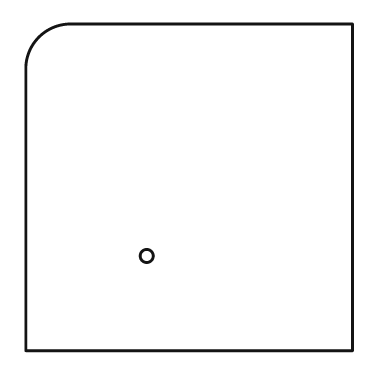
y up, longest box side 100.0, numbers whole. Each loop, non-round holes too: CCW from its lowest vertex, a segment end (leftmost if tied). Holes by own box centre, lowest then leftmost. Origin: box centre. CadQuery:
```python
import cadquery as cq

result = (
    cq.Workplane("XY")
    .moveTo(-50.0, -50.0)
    .lineTo(50.0, -50.0)
    .lineTo(50.0, 50.0)
    .lineTo(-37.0, 50.0)
    .threePointArc((-46.0, 46.0), (-50.0, 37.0))
    .close()
    .moveTo(-13.0, -21.0)
    .circle(2.0)
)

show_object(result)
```